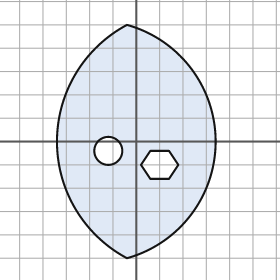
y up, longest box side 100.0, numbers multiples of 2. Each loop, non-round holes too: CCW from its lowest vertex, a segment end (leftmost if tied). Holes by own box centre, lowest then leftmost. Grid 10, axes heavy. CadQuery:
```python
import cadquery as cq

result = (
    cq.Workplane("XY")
    .moveTo(-4.0, -50.0)
    .threePointArc((34.0, 0.0), (-4.0, 50.0))
    .threePointArc((-34.0, 0.0), (-4.0, -50.0))
    .close()
    .moveTo(6.0, -16.0)
    .lineTo(14.0, -16.0)
    .lineTo(18.0, -10.0)
    .lineTo(14.0, -4.0)
    .lineTo(6.0, -4.0)
    .lineTo(2.0, -10.0)
    .close()
    .moveTo(-12.0, -4.0)
    .circle(6.0)
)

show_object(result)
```